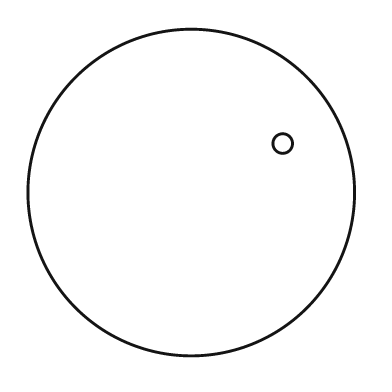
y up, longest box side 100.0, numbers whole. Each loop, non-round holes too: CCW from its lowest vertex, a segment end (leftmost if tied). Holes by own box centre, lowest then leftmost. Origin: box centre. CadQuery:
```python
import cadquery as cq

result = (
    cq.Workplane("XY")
    .moveTo(0.0, 0.0)
    .circle(50.0)
    .moveTo(28.0, 15.0)
    .circle(3.0)
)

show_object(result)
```